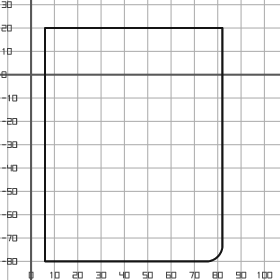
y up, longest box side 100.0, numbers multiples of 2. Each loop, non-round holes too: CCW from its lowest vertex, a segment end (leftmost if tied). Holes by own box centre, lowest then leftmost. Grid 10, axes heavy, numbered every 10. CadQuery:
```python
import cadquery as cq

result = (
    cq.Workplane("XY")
    .moveTo(6.0, -80.0)
    .lineTo(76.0, -80.0)
    .threePointArc((80.0, -78.0), (82.0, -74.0))
    .lineTo(82.0, 20.0)
    .lineTo(6.0, 20.0)
    .close()
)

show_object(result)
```